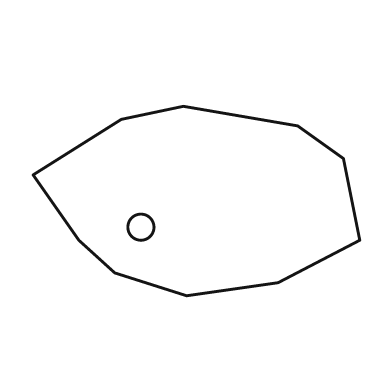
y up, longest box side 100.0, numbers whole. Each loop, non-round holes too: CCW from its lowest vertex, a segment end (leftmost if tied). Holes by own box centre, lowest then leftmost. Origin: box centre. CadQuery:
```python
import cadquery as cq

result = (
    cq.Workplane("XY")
    .moveTo(-3.0, -29.0)
    .lineTo(25.0, -25.0)
    .lineTo(50.0, -12.0)
    .lineTo(45.0, 13.0)
    .lineTo(31.0, 23.0)
    .lineTo(-4.0, 29.0)
    .lineTo(-23.0, 25.0)
    .lineTo(-50.0, 8.0)
    .lineTo(-36.0, -12.0)
    .lineTo(-25.0, -22.0)
    .close()
    .moveTo(-17.0, -8.0)
    .circle(4.0)
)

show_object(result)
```